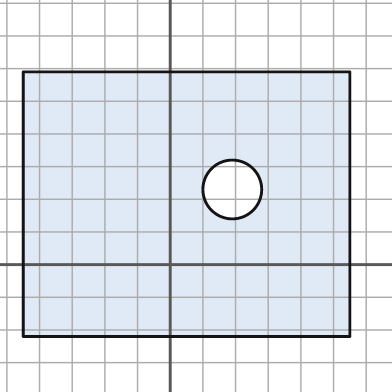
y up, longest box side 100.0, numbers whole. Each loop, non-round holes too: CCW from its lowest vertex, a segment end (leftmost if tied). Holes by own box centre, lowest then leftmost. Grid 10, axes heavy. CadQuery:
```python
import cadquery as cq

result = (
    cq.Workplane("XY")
    .moveTo(-45.0, -22.0)
    .lineTo(55.0, -22.0)
    .lineTo(55.0, 59.0)
    .lineTo(-45.0, 59.0)
    .close()
    .moveTo(19.0, 23.0)
    .circle(9.0)
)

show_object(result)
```